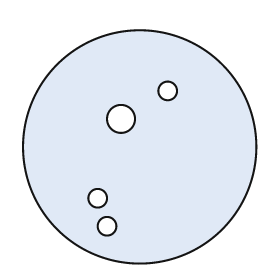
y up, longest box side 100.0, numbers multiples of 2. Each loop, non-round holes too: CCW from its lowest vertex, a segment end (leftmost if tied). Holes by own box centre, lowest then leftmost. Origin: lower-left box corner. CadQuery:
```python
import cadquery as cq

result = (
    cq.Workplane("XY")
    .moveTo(50.0, 50.0)
    .circle(50.0)
    .moveTo(36.0, 16.0)
    .circle(4.0)
    .moveTo(32.0, 28.0)
    .circle(4.0)
    .moveTo(42.0, 62.0)
    .circle(6.0)
    .moveTo(62.0, 74.0)
    .circle(4.0)
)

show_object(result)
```